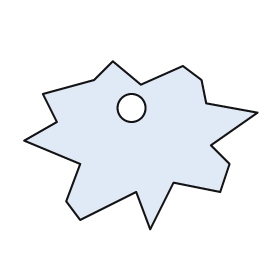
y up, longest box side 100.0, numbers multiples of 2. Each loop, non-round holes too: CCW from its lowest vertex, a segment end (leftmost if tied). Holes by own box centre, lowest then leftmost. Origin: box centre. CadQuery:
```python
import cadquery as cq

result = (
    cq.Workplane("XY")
    .moveTo(4.0, -36.0)
    .lineTo(14.0, -16.0)
    .lineTo(34.0, -20.0)
    .lineTo(38.0, -8.0)
    .lineTo(30.0, 0.0)
    .lineTo(50.0, 14.0)
    .lineTo(28.0, 18.0)
    .lineTo(26.0, 28.0)
    .lineTo(18.0, 34.0)
    .lineTo(0.0, 26.0)
    .lineTo(-12.0, 36.0)
    .lineTo(-20.0, 28.0)
    .lineTo(-42.0, 22.0)
    .lineTo(-36.0, 10.0)
    .lineTo(-50.0, 2.0)
    .lineTo(-26.0, -8.0)
    .lineTo(-32.0, -24.0)
    .lineTo(-26.0, -32.0)
    .lineTo(-2.0, -20.0)
    .close()
    .moveTo(-4.0, 16.0)
    .circle(6.0)
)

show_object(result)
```